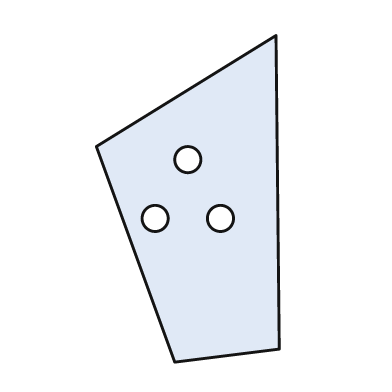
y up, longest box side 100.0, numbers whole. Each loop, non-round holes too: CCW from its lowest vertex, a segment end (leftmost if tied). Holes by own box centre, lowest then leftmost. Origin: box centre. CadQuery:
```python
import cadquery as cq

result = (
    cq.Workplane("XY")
    .moveTo(-4.0, -50.0)
    .lineTo(28.0, -46.0)
    .lineTo(27.0, 50.0)
    .lineTo(-28.0, 16.0)
    .close()
    .moveTo(-10.0, -6.0)
    .circle(4.0)
    .moveTo(10.0, -6.0)
    .circle(4.0)
    .moveTo(0.0, 12.0)
    .circle(4.0)
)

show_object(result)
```